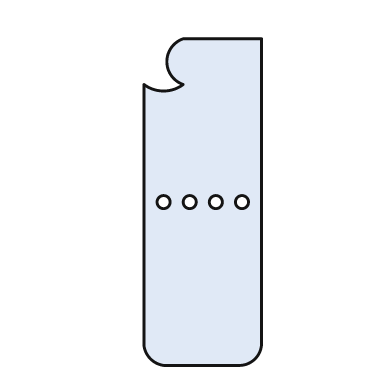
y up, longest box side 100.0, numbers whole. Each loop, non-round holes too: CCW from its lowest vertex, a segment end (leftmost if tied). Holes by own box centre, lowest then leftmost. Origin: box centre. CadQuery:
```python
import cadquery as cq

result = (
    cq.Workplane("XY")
    .moveTo(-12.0, -50.0)
    .lineTo(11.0, -50.0)
    .threePointArc((16.0, -48.0), (18.0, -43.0))
    .lineTo(18.0, 50.0)
    .lineTo(-6.0, 50.0)
    .threePointArc((-11.0, 43.0), (-6.0, 36.0))
    .threePointArc((-12.0, 34.0), (-18.0, 36.0))
    .lineTo(-18.0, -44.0)
    .threePointArc((-16.0, -48.0), (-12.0, -50.0))
    .close()
    .moveTo(-12.0, 0.0)
    .circle(2.0)
    .moveTo(-4.0, 0.0)
    .circle(2.0)
    .moveTo(4.0, 0.0)
    .circle(2.0)
    .moveTo(12.0, 0.0)
    .circle(2.0)
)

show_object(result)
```